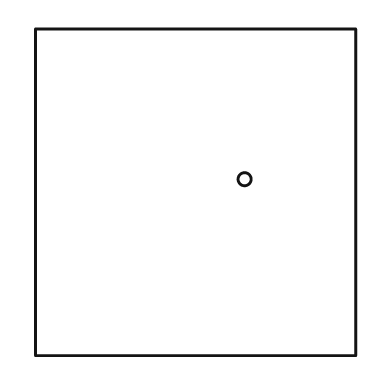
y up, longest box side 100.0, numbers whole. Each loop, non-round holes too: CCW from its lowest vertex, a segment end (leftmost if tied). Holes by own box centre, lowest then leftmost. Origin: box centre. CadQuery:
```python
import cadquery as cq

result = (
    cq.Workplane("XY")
    .moveTo(-49.0, -50.0)
    .lineTo(49.0, -50.0)
    .lineTo(49.0, 50.0)
    .lineTo(-49.0, 50.0)
    .close()
    .moveTo(15.0, 4.0)
    .circle(2.0)
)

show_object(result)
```